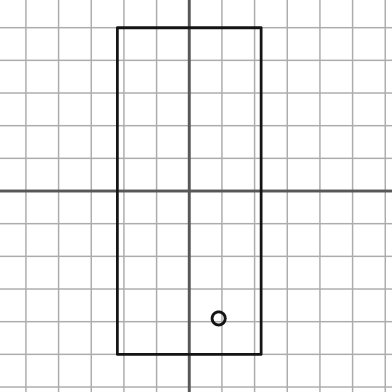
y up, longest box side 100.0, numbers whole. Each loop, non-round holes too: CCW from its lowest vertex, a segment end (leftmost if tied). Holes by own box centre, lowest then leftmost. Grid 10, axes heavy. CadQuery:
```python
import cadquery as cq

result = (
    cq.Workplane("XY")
    .moveTo(-22.0, -50.0)
    .lineTo(22.0, -50.0)
    .lineTo(22.0, 50.0)
    .lineTo(-22.0, 50.0)
    .close()
    .moveTo(9.0, -39.0)
    .circle(2.0)
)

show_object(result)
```